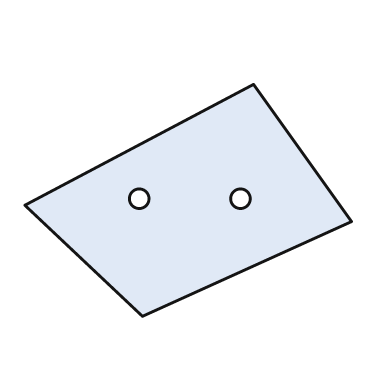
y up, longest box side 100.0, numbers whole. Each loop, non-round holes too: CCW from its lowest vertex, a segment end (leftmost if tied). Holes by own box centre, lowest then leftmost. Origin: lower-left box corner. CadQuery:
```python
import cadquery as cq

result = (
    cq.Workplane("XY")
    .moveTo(36.0, 0.0)
    .lineTo(100.0, 29.0)
    .lineTo(70.0, 71.0)
    .lineTo(0.0, 34.0)
    .close()
    .moveTo(35.0, 36.0)
    .circle(3.0)
    .moveTo(66.0, 36.0)
    .circle(3.0)
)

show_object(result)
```